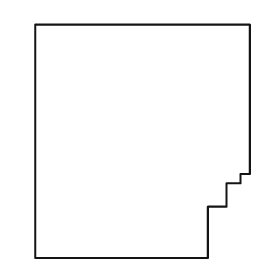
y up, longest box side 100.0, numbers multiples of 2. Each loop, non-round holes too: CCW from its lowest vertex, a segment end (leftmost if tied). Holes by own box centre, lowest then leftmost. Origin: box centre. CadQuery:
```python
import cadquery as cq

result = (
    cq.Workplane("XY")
    .moveTo(-46.0, -50.0)
    .lineTo(28.0, -50.0)
    .lineTo(28.0, -28.0)
    .lineTo(36.0, -28.0)
    .lineTo(36.0, -18.0)
    .lineTo(42.0, -18.0)
    .lineTo(42.0, -14.0)
    .lineTo(46.0, -14.0)
    .lineTo(46.0, 50.0)
    .lineTo(-46.0, 50.0)
    .close()
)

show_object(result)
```